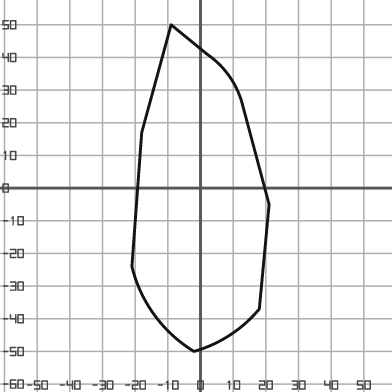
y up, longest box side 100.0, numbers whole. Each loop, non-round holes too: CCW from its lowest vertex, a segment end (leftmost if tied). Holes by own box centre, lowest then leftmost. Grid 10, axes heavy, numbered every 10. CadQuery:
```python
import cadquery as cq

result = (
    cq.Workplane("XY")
    .moveTo(-2.0, -50.0)
    .threePointArc((9.0, -45.0), (18.0, -37.0))
    .lineTo(21.0, -5.0)
    .lineTo(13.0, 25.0)
    .threePointArc((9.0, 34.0), (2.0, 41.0))
    .lineTo(-9.0, 50.0)
    .lineTo(-18.0, 17.0)
    .lineTo(-21.0, -24.0)
    .threePointArc((-14.0, -39.0), (-2.0, -50.0))
    .close()
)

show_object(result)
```